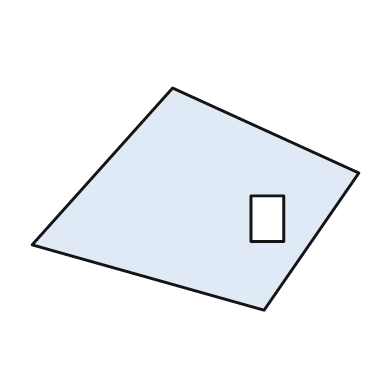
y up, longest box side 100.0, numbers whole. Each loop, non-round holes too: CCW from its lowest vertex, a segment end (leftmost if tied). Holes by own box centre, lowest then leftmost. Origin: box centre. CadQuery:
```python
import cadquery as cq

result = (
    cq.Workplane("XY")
    .moveTo(21.0, -34.0)
    .lineTo(50.0, 8.0)
    .lineTo(-7.0, 34.0)
    .lineTo(-50.0, -14.0)
    .close()
    .moveTo(17.0, -13.0)
    .lineTo(27.0, -13.0)
    .lineTo(27.0, 1.0)
    .lineTo(17.0, 1.0)
    .close()
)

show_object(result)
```